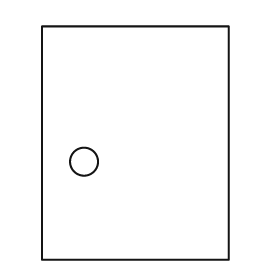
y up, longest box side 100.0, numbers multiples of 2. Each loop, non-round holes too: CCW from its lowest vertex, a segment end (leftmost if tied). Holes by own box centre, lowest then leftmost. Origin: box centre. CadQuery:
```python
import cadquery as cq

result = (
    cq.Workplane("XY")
    .moveTo(-40.0, -50.0)
    .lineTo(40.0, -50.0)
    .lineTo(40.0, 50.0)
    .lineTo(-40.0, 50.0)
    .close()
    .moveTo(-22.0, -8.0)
    .circle(6.0)
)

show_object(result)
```